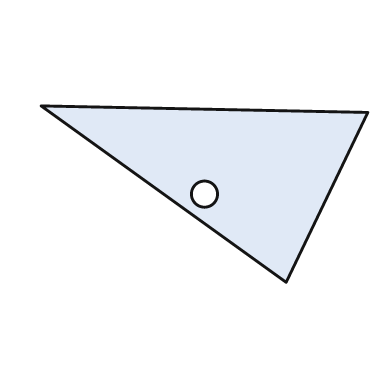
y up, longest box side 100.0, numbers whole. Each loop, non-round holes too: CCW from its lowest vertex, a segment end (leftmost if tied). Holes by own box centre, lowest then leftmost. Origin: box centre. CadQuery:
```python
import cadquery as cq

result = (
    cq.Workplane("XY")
    .moveTo(25.0, -27.0)
    .lineTo(50.0, 25.0)
    .lineTo(-50.0, 27.0)
    .close()
    .moveTo(0.0, 0.0)
    .circle(4.0)
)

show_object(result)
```